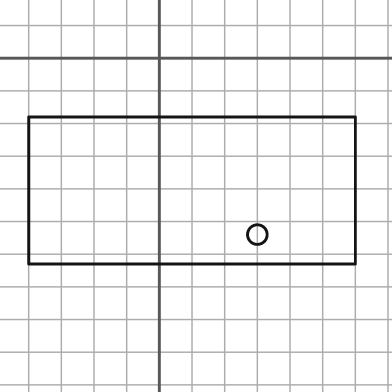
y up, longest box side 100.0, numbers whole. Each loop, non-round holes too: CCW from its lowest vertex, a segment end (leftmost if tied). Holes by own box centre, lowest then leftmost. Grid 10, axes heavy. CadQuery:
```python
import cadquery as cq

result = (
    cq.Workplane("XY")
    .moveTo(-40.0, -63.0)
    .lineTo(60.0, -63.0)
    .lineTo(60.0, -18.0)
    .lineTo(-40.0, -18.0)
    .close()
    .moveTo(30.0, -54.0)
    .circle(3.0)
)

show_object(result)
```